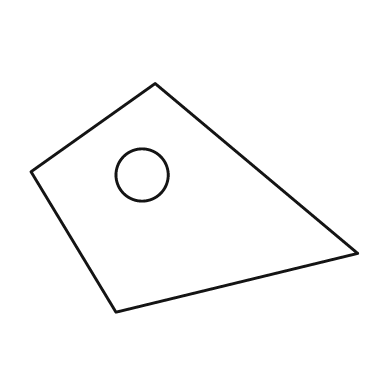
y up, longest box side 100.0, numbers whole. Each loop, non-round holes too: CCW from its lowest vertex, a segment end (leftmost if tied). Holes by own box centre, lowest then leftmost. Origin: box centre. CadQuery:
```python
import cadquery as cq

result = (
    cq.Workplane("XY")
    .moveTo(-24.0, -35.0)
    .lineTo(50.0, -17.0)
    .lineTo(-12.0, 35.0)
    .lineTo(-50.0, 8.0)
    .close()
    .moveTo(-16.0, 7.0)
    .circle(8.0)
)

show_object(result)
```